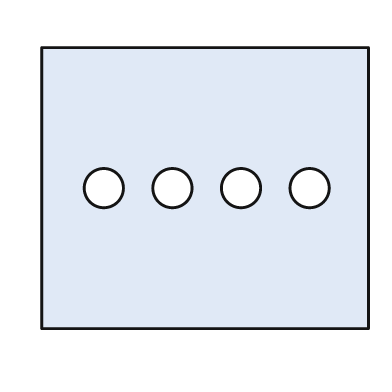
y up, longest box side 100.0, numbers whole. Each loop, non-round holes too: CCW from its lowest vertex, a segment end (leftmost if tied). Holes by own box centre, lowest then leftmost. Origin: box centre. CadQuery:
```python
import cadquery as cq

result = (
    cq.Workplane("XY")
    .moveTo(-50.0, -43.0)
    .lineTo(50.0, -43.0)
    .lineTo(50.0, 43.0)
    .lineTo(-50.0, 43.0)
    .close()
    .moveTo(-31.0, 0.0)
    .circle(6.0)
    .moveTo(-10.0, 0.0)
    .circle(6.0)
    .moveTo(11.0, 0.0)
    .circle(6.0)
    .moveTo(32.0, 0.0)
    .circle(6.0)
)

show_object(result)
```